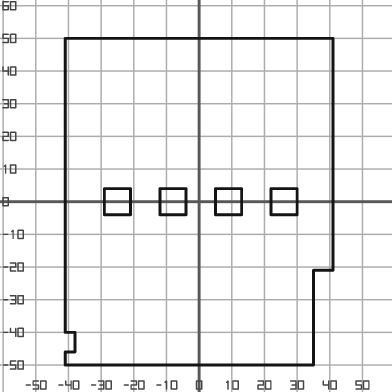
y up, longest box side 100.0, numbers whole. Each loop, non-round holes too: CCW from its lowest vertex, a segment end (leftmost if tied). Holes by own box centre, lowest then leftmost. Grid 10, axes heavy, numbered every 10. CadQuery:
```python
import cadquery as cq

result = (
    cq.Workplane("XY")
    .moveTo(-41.0, -50.0)
    .lineTo(35.0, -50.0)
    .lineTo(35.0, -21.0)
    .lineTo(41.0, -21.0)
    .lineTo(41.0, 50.0)
    .lineTo(-41.0, 50.0)
    .lineTo(-41.0, -40.0)
    .lineTo(-38.0, -40.0)
    .lineTo(-38.0, -46.0)
    .lineTo(-41.0, -46.0)
    .close()
    .moveTo(-29.0, -4.0)
    .lineTo(-21.0, -4.0)
    .lineTo(-21.0, 4.0)
    .lineTo(-29.0, 4.0)
    .close()
    .moveTo(-12.0, -4.0)
    .lineTo(-4.0, -4.0)
    .lineTo(-4.0, 4.0)
    .lineTo(-12.0, 4.0)
    .close()
    .moveTo(5.0, -4.0)
    .lineTo(13.0, -4.0)
    .lineTo(13.0, 4.0)
    .lineTo(5.0, 4.0)
    .close()
    .moveTo(22.0, -4.0)
    .lineTo(30.0, -4.0)
    .lineTo(30.0, 4.0)
    .lineTo(22.0, 4.0)
    .close()
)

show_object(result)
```